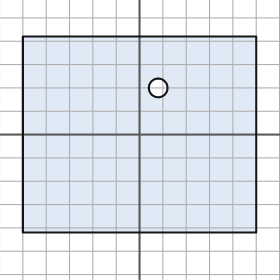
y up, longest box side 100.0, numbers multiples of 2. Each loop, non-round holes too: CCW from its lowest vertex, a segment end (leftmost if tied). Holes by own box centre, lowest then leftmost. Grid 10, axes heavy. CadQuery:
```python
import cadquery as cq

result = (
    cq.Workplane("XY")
    .moveTo(-50.0, -42.0)
    .lineTo(50.0, -42.0)
    .lineTo(50.0, 42.0)
    .lineTo(-50.0, 42.0)
    .close()
    .moveTo(8.0, 20.0)
    .circle(4.0)
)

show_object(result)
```